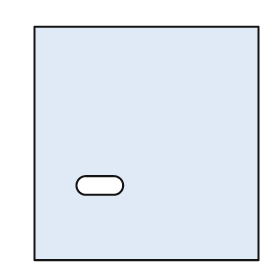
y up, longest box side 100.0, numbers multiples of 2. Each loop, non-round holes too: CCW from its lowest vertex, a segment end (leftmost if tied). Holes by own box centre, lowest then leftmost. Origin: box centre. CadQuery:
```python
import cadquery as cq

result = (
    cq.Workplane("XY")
    .moveTo(-48.0, -50.0)
    .lineTo(48.0, -50.0)
    .lineTo(48.0, 50.0)
    .lineTo(-48.0, 50.0)
    .close()
    .moveTo(-26.0, -22.0)
    .lineTo(-14.0, -22.0)
    .threePointArc((-10.0, -18.0), (-14.0, -14.0))
    .lineTo(-26.0, -14.0)
    .threePointArc((-30.0, -18.0), (-26.0, -22.0))
    .close()
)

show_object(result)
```